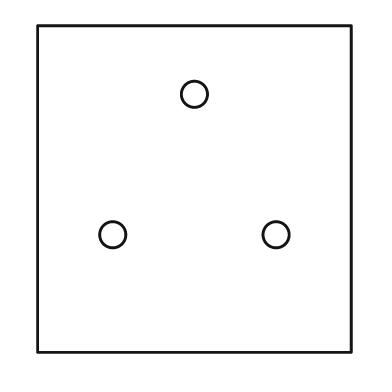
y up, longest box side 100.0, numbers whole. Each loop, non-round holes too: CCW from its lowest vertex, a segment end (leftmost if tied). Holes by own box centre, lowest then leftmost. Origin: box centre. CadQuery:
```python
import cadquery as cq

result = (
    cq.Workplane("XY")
    .moveTo(-48.0, -50.0)
    .lineTo(48.0, -50.0)
    .lineTo(48.0, 50.0)
    .lineTo(-48.0, 50.0)
    .close()
    .moveTo(-25.0, -14.0)
    .circle(4.0)
    .moveTo(25.0, -14.0)
    .circle(4.0)
    .moveTo(0.0, 29.0)
    .circle(4.0)
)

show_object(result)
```